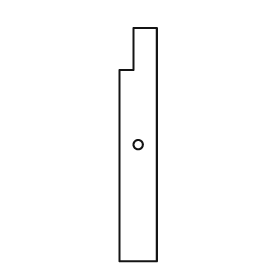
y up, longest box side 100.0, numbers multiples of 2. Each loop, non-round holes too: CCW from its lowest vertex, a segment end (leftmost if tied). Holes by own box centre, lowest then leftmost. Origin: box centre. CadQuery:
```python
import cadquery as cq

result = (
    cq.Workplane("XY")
    .moveTo(-8.0, -50.0)
    .lineTo(8.0, -50.0)
    .lineTo(8.0, 50.0)
    .lineTo(-2.0, 50.0)
    .lineTo(-2.0, 32.0)
    .lineTo(-8.0, 32.0)
    .close()
    .moveTo(0.0, 0.0)
    .circle(2.0)
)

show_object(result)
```